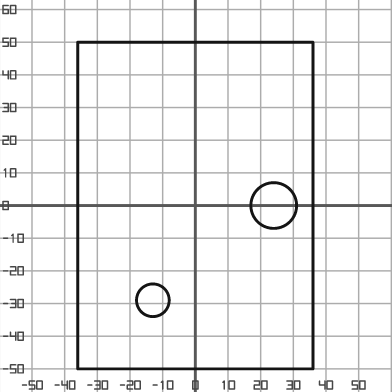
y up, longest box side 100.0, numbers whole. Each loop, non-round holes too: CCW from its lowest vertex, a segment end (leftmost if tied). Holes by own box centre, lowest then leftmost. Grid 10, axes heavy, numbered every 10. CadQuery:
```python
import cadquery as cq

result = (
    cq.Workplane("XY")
    .moveTo(-36.0, -50.0)
    .lineTo(36.0, -50.0)
    .lineTo(36.0, 50.0)
    .lineTo(-36.0, 50.0)
    .close()
    .moveTo(-13.0, -29.0)
    .circle(5.0)
    .moveTo(24.0, 0.0)
    .circle(7.0)
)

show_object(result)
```